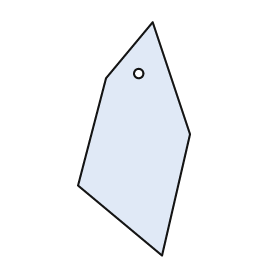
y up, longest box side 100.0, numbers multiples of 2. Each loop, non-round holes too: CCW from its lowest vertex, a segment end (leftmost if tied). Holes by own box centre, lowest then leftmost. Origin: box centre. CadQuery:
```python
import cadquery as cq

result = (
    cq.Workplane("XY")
    .moveTo(12.0, -50.0)
    .lineTo(24.0, 2.0)
    .lineTo(8.0, 50.0)
    .lineTo(-12.0, 26.0)
    .lineTo(-24.0, -20.0)
    .close()
    .moveTo(2.0, 28.0)
    .circle(2.0)
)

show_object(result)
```